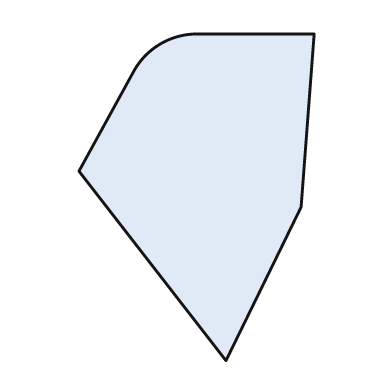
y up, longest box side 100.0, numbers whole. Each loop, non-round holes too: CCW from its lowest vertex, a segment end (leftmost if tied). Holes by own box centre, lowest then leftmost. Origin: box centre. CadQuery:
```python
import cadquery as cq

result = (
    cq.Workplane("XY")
    .moveTo(9.0, -50.0)
    .lineTo(32.0, -3.0)
    .lineTo(36.0, 50.0)
    .lineTo(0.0, 50.0)
    .threePointArc((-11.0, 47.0), (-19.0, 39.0))
    .lineTo(-36.0, 8.0)
    .close()
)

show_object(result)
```